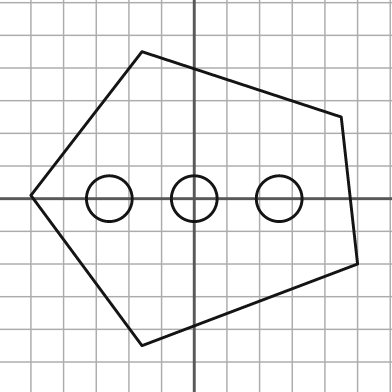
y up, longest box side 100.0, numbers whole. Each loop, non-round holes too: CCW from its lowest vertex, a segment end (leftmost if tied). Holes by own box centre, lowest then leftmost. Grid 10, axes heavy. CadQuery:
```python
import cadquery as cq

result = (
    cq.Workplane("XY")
    .moveTo(-16.0, -45.0)
    .lineTo(50.0, -20.0)
    .lineTo(45.0, 25.0)
    .lineTo(-16.0, 45.0)
    .lineTo(-50.0, 1.0)
    .close()
    .moveTo(-26.0, 0.0)
    .circle(7.0)
    .moveTo(0.0, 0.0)
    .circle(7.0)
    .moveTo(26.0, 0.0)
    .circle(7.0)
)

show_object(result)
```